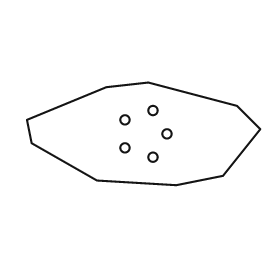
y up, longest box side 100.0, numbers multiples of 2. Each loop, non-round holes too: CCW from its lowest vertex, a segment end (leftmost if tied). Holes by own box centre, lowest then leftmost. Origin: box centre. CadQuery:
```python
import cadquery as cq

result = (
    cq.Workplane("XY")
    .moveTo(14.0, -22.0)
    .lineTo(34.0, -18.0)
    .lineTo(50.0, 2.0)
    .lineTo(40.0, 12.0)
    .lineTo(2.0, 22.0)
    .lineTo(-16.0, 20.0)
    .lineTo(-50.0, 6.0)
    .lineTo(-48.0, -4.0)
    .lineTo(-20.0, -20.0)
    .close()
    .moveTo(4.0, -10.0)
    .circle(2.0)
    .moveTo(-8.0, -6.0)
    .circle(2.0)
    .moveTo(10.0, 0.0)
    .circle(2.0)
    .moveTo(-8.0, 6.0)
    .circle(2.0)
    .moveTo(4.0, 10.0)
    .circle(2.0)
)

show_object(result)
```